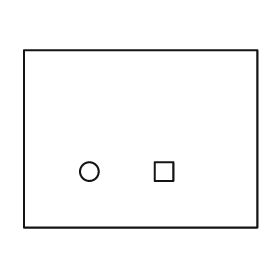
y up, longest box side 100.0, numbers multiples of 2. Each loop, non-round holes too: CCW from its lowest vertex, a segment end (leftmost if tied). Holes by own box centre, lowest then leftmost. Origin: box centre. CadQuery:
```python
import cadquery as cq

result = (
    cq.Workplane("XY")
    .moveTo(-50.0, -38.0)
    .lineTo(50.0, -38.0)
    .lineTo(50.0, 38.0)
    .lineTo(-50.0, 38.0)
    .close()
    .moveTo(-22.0, -14.0)
    .circle(4.0)
    .moveTo(6.0, -18.0)
    .lineTo(14.0, -18.0)
    .lineTo(14.0, -10.0)
    .lineTo(6.0, -10.0)
    .close()
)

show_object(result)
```